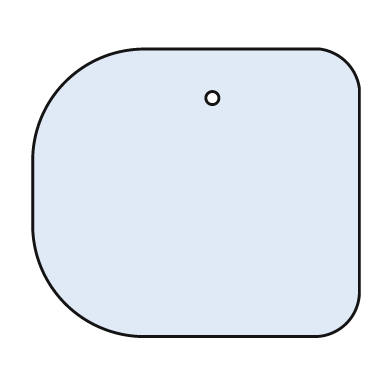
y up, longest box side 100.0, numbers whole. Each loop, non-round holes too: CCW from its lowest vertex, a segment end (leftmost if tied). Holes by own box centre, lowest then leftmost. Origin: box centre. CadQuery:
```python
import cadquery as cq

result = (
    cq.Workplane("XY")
    .moveTo(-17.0, -44.0)
    .lineTo(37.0, -44.0)
    .threePointArc((46.0, -40.0), (50.0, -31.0))
    .lineTo(50.0, 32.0)
    .threePointArc((46.0, 40.0), (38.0, 44.0))
    .lineTo(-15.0, 44.0)
    .threePointArc((-40.0, 34.0), (-50.0, 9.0))
    .lineTo(-50.0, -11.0)
    .threePointArc((-40.0, -34.0), (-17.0, -44.0))
    .close()
    .moveTo(5.0, 29.0)
    .circle(2.0)
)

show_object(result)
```